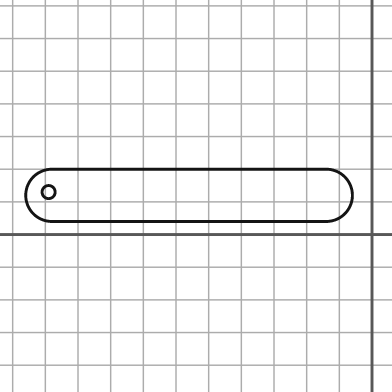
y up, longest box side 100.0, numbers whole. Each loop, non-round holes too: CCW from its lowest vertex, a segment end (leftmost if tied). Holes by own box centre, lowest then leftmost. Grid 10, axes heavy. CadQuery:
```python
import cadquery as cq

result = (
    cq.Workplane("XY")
    .moveTo(-98.0, 4.0)
    .lineTo(-14.0, 4.0)
    .threePointArc((-6.0, 12.0), (-14.0, 20.0))
    .lineTo(-98.0, 20.0)
    .threePointArc((-106.0, 12.0), (-98.0, 4.0))
    .close()
    .moveTo(-99.0, 13.0)
    .circle(2.0)
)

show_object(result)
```